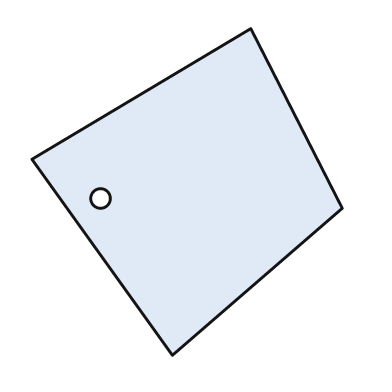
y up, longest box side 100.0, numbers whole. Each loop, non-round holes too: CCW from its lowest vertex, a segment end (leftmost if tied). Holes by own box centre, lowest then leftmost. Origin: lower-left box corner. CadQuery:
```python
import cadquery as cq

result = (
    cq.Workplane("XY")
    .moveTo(43.0, 0.0)
    .lineTo(95.0, 45.0)
    .lineTo(67.0, 100.0)
    .lineTo(0.0, 60.0)
    .close()
    .moveTo(21.0, 48.0)
    .circle(3.0)
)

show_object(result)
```